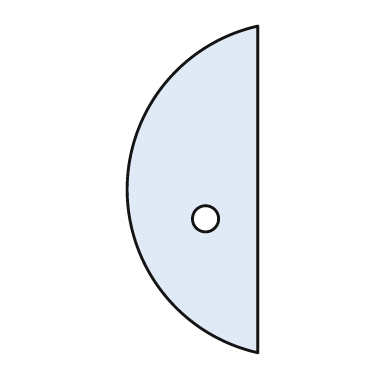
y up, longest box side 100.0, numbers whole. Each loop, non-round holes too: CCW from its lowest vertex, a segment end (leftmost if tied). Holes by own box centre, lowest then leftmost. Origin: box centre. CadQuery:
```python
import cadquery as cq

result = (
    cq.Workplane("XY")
    .moveTo(20.0, -50.0)
    .lineTo(20.0, 50.0)
    .threePointArc((-20.0, 0.0), (20.0, -50.0))
    .close()
    .moveTo(4.0, -9.0)
    .circle(4.0)
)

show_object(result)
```